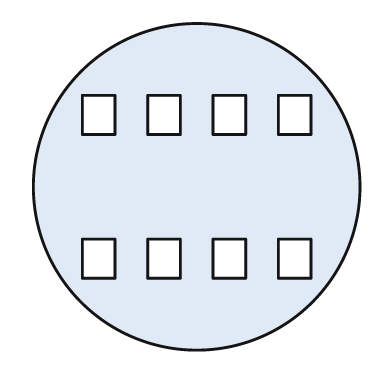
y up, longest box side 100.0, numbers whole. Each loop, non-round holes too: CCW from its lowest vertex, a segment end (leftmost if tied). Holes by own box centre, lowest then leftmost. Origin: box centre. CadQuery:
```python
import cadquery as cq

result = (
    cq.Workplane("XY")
    .moveTo(0.0, 0.0)
    .circle(50.0)
    .moveTo(-35.0, -28.0)
    .lineTo(-25.0, -28.0)
    .lineTo(-25.0, -16.0)
    .lineTo(-35.0, -16.0)
    .close()
    .moveTo(-15.0, -28.0)
    .lineTo(-5.0, -28.0)
    .lineTo(-5.0, -16.0)
    .lineTo(-15.0, -16.0)
    .close()
    .moveTo(5.0, -28.0)
    .lineTo(15.0, -28.0)
    .lineTo(15.0, -16.0)
    .lineTo(5.0, -16.0)
    .close()
    .moveTo(25.0, -28.0)
    .lineTo(35.0, -28.0)
    .lineTo(35.0, -16.0)
    .lineTo(25.0, -16.0)
    .close()
    .moveTo(-35.0, 16.0)
    .lineTo(-25.0, 16.0)
    .lineTo(-25.0, 28.0)
    .lineTo(-35.0, 28.0)
    .close()
    .moveTo(-15.0, 16.0)
    .lineTo(-5.0, 16.0)
    .lineTo(-5.0, 28.0)
    .lineTo(-15.0, 28.0)
    .close()
    .moveTo(5.0, 16.0)
    .lineTo(15.0, 16.0)
    .lineTo(15.0, 28.0)
    .lineTo(5.0, 28.0)
    .close()
    .moveTo(25.0, 16.0)
    .lineTo(35.0, 16.0)
    .lineTo(35.0, 28.0)
    .lineTo(25.0, 28.0)
    .close()
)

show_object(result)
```